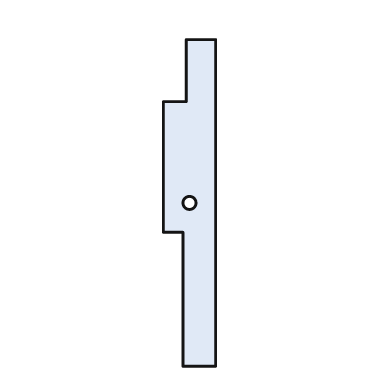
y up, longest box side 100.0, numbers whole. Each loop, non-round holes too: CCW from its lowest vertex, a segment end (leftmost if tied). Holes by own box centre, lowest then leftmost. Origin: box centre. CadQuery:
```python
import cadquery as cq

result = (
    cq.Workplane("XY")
    .moveTo(-2.0, -50.0)
    .lineTo(8.0, -50.0)
    .lineTo(8.0, 50.0)
    .lineTo(-1.0, 50.0)
    .lineTo(-1.0, 31.0)
    .lineTo(-8.0, 31.0)
    .lineTo(-8.0, -9.0)
    .lineTo(-2.0, -9.0)
    .close()
    .moveTo(0.0, 0.0)
    .circle(2.0)
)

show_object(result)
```